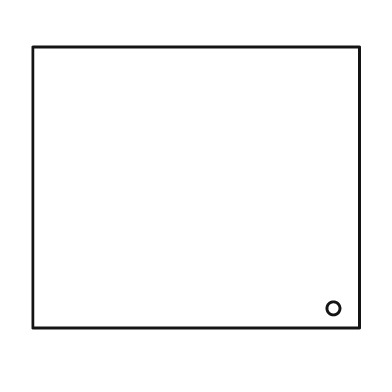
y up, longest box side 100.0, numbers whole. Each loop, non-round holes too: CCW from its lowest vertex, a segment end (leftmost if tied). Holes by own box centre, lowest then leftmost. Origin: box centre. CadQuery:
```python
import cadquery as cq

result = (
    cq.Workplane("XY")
    .moveTo(-50.0, -43.0)
    .lineTo(50.0, -43.0)
    .lineTo(50.0, 43.0)
    .lineTo(-50.0, 43.0)
    .close()
    .moveTo(42.0, -37.0)
    .circle(2.0)
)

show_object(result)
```